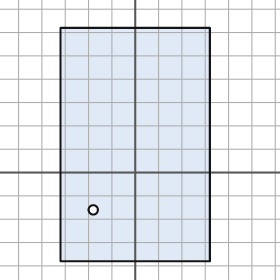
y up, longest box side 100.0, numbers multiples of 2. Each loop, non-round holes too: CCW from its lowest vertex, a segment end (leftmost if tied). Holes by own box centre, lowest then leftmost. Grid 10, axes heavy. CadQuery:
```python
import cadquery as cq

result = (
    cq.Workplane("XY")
    .moveTo(-32.0, -38.0)
    .lineTo(32.0, -38.0)
    .lineTo(32.0, 62.0)
    .lineTo(-32.0, 62.0)
    .close()
    .moveTo(-18.0, -16.0)
    .circle(2.0)
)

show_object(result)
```